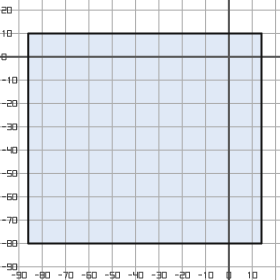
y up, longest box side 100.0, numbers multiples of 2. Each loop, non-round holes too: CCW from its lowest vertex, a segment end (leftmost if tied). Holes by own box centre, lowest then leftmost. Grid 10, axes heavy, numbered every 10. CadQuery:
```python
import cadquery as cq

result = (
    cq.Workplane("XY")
    .moveTo(-86.0, -80.0)
    .lineTo(14.0, -80.0)
    .lineTo(14.0, 10.0)
    .lineTo(-86.0, 10.0)
    .close()
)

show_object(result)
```